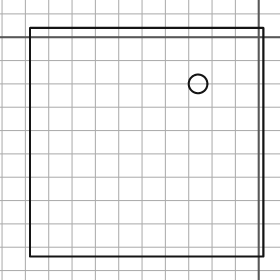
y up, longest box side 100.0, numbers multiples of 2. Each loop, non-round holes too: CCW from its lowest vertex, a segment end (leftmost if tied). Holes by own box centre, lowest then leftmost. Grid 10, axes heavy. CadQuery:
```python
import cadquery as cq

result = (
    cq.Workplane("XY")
    .moveTo(-98.0, -94.0)
    .lineTo(2.0, -94.0)
    .lineTo(2.0, 4.0)
    .lineTo(-98.0, 4.0)
    .close()
    .moveTo(-26.0, -20.0)
    .circle(4.0)
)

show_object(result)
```